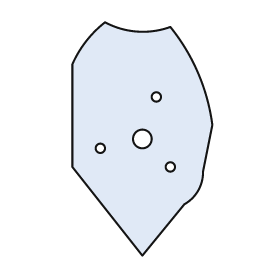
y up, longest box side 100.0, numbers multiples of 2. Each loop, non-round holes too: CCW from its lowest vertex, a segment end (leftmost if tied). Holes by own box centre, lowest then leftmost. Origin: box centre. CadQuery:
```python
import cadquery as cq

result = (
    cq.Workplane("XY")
    .moveTo(0.0, -50.0)
    .lineTo(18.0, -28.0)
    .threePointArc((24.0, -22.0), (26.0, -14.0))
    .lineTo(30.0, 6.0)
    .threePointArc((24.0, 28.0), (12.0, 48.0))
    .threePointArc((-2.0, 46.0), (-16.0, 50.0))
    .threePointArc((-24.0, 42.0), (-30.0, 32.0))
    .lineTo(-30.0, -12.0)
    .close()
    .moveTo(12.0, -12.0)
    .circle(2.0)
    .moveTo(-18.0, -4.0)
    .circle(2.0)
    .moveTo(0.0, 0.0)
    .circle(4.0)
    .moveTo(6.0, 18.0)
    .circle(2.0)
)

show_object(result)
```